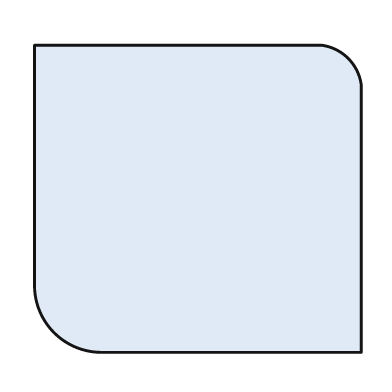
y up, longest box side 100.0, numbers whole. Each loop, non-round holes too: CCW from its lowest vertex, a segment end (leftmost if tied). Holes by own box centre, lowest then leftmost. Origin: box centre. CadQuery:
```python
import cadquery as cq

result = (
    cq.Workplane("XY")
    .moveTo(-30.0, -47.0)
    .lineTo(50.0, -47.0)
    .lineTo(50.0, 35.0)
    .threePointArc((46.0, 43.0), (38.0, 47.0))
    .lineTo(-50.0, 47.0)
    .lineTo(-50.0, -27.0)
    .threePointArc((-44.0, -41.0), (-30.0, -47.0))
    .close()
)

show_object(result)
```